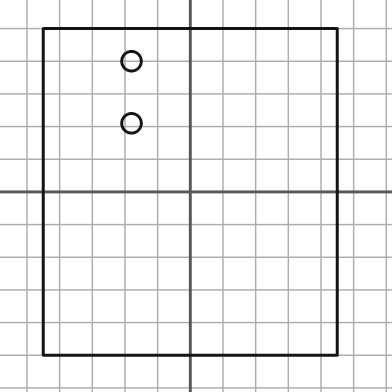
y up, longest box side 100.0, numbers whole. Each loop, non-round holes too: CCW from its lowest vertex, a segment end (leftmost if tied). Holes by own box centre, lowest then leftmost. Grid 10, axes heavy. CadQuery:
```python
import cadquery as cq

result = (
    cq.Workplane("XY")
    .moveTo(-45.0, -50.0)
    .lineTo(45.0, -50.0)
    .lineTo(45.0, 50.0)
    .lineTo(-45.0, 50.0)
    .close()
    .moveTo(-18.0, 21.0)
    .circle(3.0)
    .moveTo(-18.0, 40.0)
    .circle(3.0)
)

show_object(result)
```